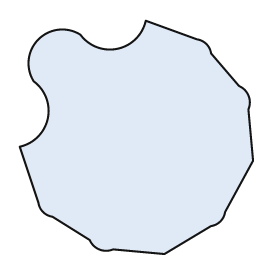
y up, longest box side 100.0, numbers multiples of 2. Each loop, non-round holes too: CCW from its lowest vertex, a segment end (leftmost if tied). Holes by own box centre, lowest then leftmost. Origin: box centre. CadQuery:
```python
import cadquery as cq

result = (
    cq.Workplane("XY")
    .moveTo(12.0, -50.0)
    .lineTo(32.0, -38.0)
    .threePointArc((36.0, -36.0), (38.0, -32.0))
    .lineTo(50.0, -10.0)
    .lineTo(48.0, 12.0)
    .threePointArc((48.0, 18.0), (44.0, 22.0))
    .lineTo(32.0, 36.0)
    .threePointArc((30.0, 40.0), (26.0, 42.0))
    .lineTo(4.0, 50.0)
    .threePointArc((-8.0, 38.0), (-24.0, 44.0))
    .threePointArc((-42.0, 42.0), (-44.0, 24.0))
    .threePointArc((-38.0, 8.0), (-50.0, -4.0))
    .lineTo(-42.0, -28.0)
    .threePointArc((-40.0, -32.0), (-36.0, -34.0))
    .lineTo(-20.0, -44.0)
    .threePointArc((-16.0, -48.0), (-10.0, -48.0))
    .close()
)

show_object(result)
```